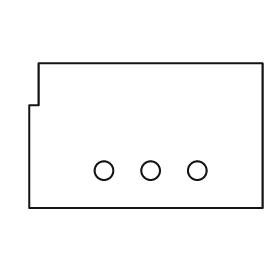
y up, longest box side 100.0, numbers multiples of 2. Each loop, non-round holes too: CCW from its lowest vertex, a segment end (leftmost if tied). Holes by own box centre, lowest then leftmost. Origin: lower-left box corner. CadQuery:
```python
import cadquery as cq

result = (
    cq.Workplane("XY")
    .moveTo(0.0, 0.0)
    .lineTo(100.0, 0.0)
    .lineTo(100.0, 62.0)
    .lineTo(4.0, 62.0)
    .lineTo(4.0, 44.0)
    .lineTo(0.0, 44.0)
    .close()
    .moveTo(32.0, 16.0)
    .circle(4.0)
    .moveTo(52.0, 16.0)
    .circle(4.0)
    .moveTo(72.0, 16.0)
    .circle(4.0)
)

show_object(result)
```